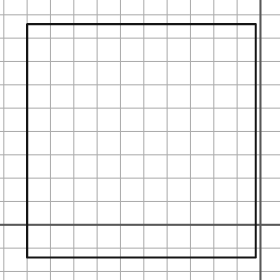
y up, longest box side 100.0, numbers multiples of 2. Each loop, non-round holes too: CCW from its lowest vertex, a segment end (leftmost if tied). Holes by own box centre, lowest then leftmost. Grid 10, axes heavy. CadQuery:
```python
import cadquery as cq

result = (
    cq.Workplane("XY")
    .moveTo(-100.0, -14.0)
    .lineTo(-2.0, -14.0)
    .lineTo(-2.0, 86.0)
    .lineTo(-100.0, 86.0)
    .close()
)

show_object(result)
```